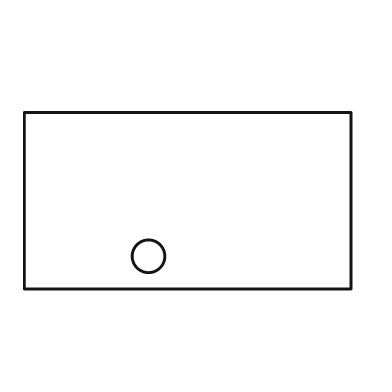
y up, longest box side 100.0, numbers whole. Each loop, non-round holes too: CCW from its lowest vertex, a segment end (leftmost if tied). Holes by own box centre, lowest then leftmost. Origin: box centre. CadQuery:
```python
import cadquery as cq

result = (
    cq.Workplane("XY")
    .moveTo(-50.0, -27.0)
    .lineTo(50.0, -27.0)
    .lineTo(50.0, 27.0)
    .lineTo(-50.0, 27.0)
    .close()
    .moveTo(-12.0, -17.0)
    .circle(5.0)
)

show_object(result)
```